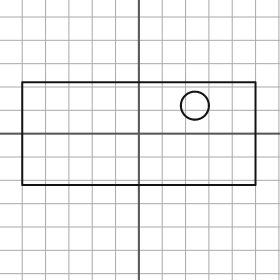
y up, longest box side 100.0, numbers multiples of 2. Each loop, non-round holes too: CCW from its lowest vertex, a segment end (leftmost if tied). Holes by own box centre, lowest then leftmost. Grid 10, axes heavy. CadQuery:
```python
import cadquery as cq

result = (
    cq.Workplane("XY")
    .moveTo(-50.0, -22.0)
    .lineTo(50.0, -22.0)
    .lineTo(50.0, 22.0)
    .lineTo(-50.0, 22.0)
    .close()
    .moveTo(24.0, 12.0)
    .circle(6.0)
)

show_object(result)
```